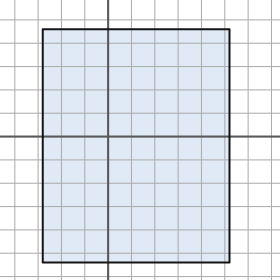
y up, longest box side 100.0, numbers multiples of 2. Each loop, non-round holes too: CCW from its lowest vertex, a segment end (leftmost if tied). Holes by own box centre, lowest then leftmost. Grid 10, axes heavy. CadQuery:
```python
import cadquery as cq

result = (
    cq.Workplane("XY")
    .moveTo(-28.0, -54.0)
    .lineTo(52.0, -54.0)
    .lineTo(52.0, 46.0)
    .lineTo(-28.0, 46.0)
    .close()
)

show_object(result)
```